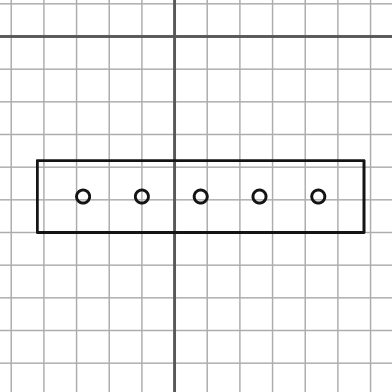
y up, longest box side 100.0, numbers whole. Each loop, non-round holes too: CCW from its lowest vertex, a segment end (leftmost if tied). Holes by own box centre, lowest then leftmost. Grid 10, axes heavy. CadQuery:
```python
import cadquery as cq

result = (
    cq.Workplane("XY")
    .moveTo(-42.0, -60.0)
    .lineTo(58.0, -60.0)
    .lineTo(58.0, -38.0)
    .lineTo(-42.0, -38.0)
    .close()
    .moveTo(-28.0, -49.0)
    .circle(2.0)
    .moveTo(-10.0, -49.0)
    .circle(2.0)
    .moveTo(8.0, -49.0)
    .circle(2.0)
    .moveTo(26.0, -49.0)
    .circle(2.0)
    .moveTo(44.0, -49.0)
    .circle(2.0)
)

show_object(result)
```